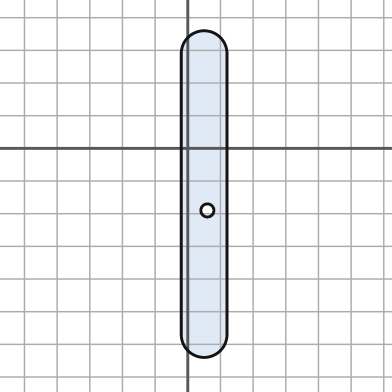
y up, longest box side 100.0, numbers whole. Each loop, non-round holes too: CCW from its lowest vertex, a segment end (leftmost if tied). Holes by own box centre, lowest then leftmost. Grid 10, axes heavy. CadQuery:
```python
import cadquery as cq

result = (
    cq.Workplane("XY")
    .moveTo(-2.0, -57.0)
    .threePointArc((5.0, -64.0), (12.0, -57.0))
    .lineTo(12.0, 29.0)
    .threePointArc((5.0, 36.0), (-2.0, 29.0))
    .close()
    .moveTo(6.0, -19.0)
    .circle(2.0)
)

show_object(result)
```